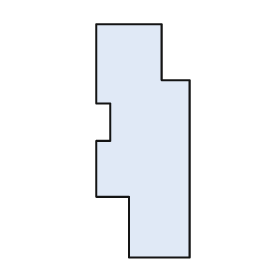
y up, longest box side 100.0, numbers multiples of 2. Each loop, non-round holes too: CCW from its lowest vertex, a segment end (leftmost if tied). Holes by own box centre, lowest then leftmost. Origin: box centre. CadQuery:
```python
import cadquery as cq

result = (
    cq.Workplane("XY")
    .moveTo(-6.0, -50.0)
    .lineTo(20.0, -50.0)
    .lineTo(20.0, 26.0)
    .lineTo(8.0, 26.0)
    .lineTo(8.0, 50.0)
    .lineTo(-20.0, 50.0)
    .lineTo(-20.0, 16.0)
    .lineTo(-14.0, 16.0)
    .lineTo(-14.0, 0.0)
    .lineTo(-20.0, 0.0)
    .lineTo(-20.0, -24.0)
    .lineTo(-6.0, -24.0)
    .close()
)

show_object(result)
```